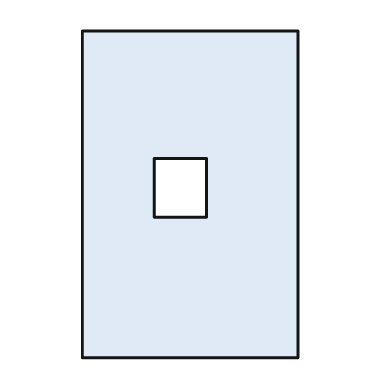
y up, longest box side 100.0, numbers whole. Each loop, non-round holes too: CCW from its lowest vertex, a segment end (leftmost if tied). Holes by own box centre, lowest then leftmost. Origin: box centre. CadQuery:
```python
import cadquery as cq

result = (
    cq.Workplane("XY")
    .moveTo(-33.0, -50.0)
    .lineTo(33.0, -50.0)
    .lineTo(33.0, 50.0)
    .lineTo(-33.0, 50.0)
    .close()
    .moveTo(-11.0, -7.0)
    .lineTo(5.0, -7.0)
    .lineTo(5.0, 11.0)
    .lineTo(-11.0, 11.0)
    .close()
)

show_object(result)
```